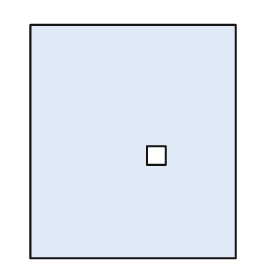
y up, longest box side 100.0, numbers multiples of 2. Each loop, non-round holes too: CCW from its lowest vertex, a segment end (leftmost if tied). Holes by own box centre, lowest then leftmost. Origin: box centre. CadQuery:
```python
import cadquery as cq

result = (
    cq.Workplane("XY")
    .moveTo(-44.0, -50.0)
    .lineTo(44.0, -50.0)
    .lineTo(44.0, 50.0)
    .lineTo(-44.0, 50.0)
    .close()
    .moveTo(6.0, -10.0)
    .lineTo(14.0, -10.0)
    .lineTo(14.0, -2.0)
    .lineTo(6.0, -2.0)
    .close()
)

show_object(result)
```